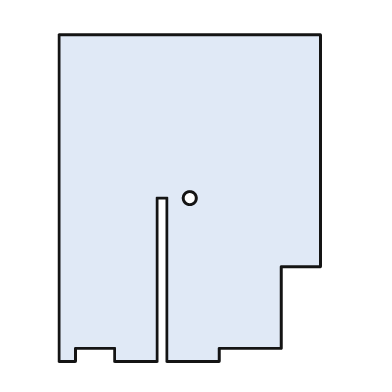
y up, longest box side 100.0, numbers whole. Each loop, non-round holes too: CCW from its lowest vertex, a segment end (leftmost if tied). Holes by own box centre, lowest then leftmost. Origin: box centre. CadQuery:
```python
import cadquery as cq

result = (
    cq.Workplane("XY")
    .moveTo(-40.0, -50.0)
    .lineTo(-35.0, -50.0)
    .lineTo(-35.0, -46.0)
    .lineTo(-23.0, -46.0)
    .lineTo(-23.0, -50.0)
    .lineTo(-10.0, -50.0)
    .lineTo(-10.0, 0.0)
    .lineTo(-7.0, 0.0)
    .lineTo(-7.0, -50.0)
    .lineTo(9.0, -50.0)
    .lineTo(9.0, -46.0)
    .lineTo(28.0, -46.0)
    .lineTo(28.0, -21.0)
    .lineTo(40.0, -21.0)
    .lineTo(40.0, 50.0)
    .lineTo(-40.0, 50.0)
    .close()
    .moveTo(0.0, 0.0)
    .circle(2.0)
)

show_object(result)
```